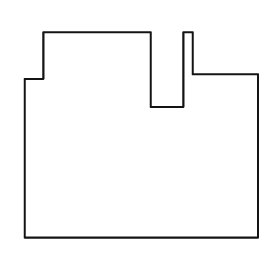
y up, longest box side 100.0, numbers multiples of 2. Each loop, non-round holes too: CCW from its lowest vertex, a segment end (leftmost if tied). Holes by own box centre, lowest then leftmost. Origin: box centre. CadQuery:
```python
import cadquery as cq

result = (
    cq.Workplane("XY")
    .moveTo(-50.0, -44.0)
    .lineTo(50.0, -44.0)
    .lineTo(50.0, 26.0)
    .lineTo(22.0, 26.0)
    .lineTo(22.0, 44.0)
    .lineTo(18.0, 44.0)
    .lineTo(18.0, 12.0)
    .lineTo(4.0, 12.0)
    .lineTo(4.0, 44.0)
    .lineTo(-42.0, 44.0)
    .lineTo(-42.0, 24.0)
    .lineTo(-50.0, 24.0)
    .close()
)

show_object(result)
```